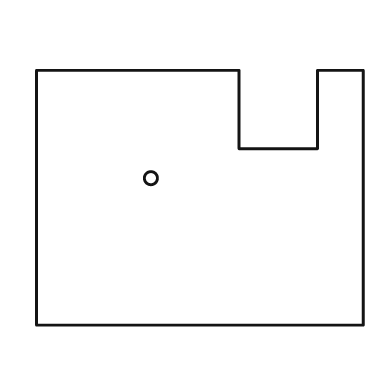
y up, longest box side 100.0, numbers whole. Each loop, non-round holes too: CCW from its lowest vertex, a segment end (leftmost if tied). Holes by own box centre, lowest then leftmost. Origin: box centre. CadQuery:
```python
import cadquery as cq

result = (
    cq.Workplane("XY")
    .moveTo(-50.0, -39.0)
    .lineTo(50.0, -39.0)
    .lineTo(50.0, 39.0)
    .lineTo(36.0, 39.0)
    .lineTo(36.0, 15.0)
    .lineTo(12.0, 15.0)
    .lineTo(12.0, 39.0)
    .lineTo(-50.0, 39.0)
    .close()
    .moveTo(-15.0, 6.0)
    .circle(2.0)
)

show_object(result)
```